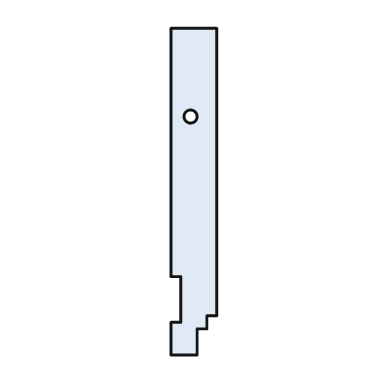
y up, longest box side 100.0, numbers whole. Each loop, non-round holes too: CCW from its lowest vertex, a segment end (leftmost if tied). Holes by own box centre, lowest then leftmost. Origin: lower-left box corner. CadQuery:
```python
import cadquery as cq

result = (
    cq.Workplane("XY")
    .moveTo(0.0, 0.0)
    .lineTo(8.0, 0.0)
    .lineTo(8.0, 8.0)
    .lineTo(11.0, 8.0)
    .lineTo(11.0, 12.0)
    .lineTo(14.0, 12.0)
    .lineTo(14.0, 100.0)
    .lineTo(0.0, 100.0)
    .lineTo(0.0, 24.0)
    .lineTo(3.0, 24.0)
    .lineTo(3.0, 10.0)
    .lineTo(0.0, 10.0)
    .close()
    .moveTo(6.0, 73.0)
    .circle(2.0)
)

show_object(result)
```